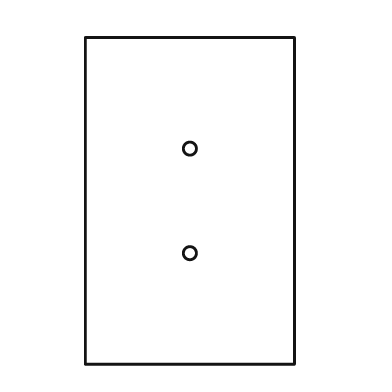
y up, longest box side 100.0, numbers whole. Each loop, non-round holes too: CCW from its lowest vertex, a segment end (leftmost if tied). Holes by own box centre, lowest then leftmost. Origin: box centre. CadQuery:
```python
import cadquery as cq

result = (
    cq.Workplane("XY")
    .moveTo(-32.0, -50.0)
    .lineTo(32.0, -50.0)
    .lineTo(32.0, 50.0)
    .lineTo(-32.0, 50.0)
    .close()
    .moveTo(0.0, -16.0)
    .circle(2.0)
    .moveTo(0.0, 16.0)
    .circle(2.0)
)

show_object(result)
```